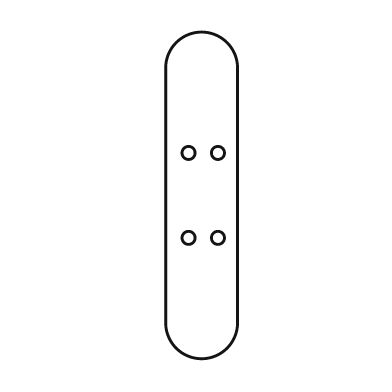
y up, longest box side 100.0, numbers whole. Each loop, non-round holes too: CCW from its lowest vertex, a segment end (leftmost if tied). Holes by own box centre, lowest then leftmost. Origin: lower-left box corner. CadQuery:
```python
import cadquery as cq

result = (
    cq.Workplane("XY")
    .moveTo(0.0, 11.0)
    .threePointArc((11.0, 0.0), (22.0, 11.0))
    .lineTo(22.0, 89.0)
    .threePointArc((11.0, 100.0), (0.0, 89.0))
    .close()
    .moveTo(7.0, 37.0)
    .circle(2.0)
    .moveTo(16.0, 37.0)
    .circle(2.0)
    .moveTo(7.0, 63.0)
    .circle(2.0)
    .moveTo(16.0, 63.0)
    .circle(2.0)
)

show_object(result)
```